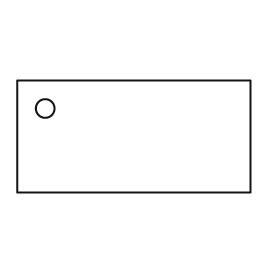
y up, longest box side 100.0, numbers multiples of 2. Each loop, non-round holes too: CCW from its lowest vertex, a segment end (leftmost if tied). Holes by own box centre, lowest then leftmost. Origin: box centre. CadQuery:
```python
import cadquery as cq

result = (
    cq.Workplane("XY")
    .moveTo(-50.0, -24.0)
    .lineTo(50.0, -24.0)
    .lineTo(50.0, 24.0)
    .lineTo(-50.0, 24.0)
    .close()
    .moveTo(-38.0, 12.0)
    .circle(4.0)
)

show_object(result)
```